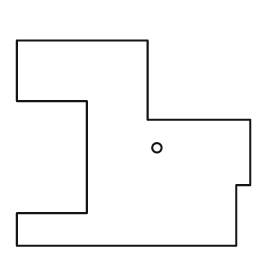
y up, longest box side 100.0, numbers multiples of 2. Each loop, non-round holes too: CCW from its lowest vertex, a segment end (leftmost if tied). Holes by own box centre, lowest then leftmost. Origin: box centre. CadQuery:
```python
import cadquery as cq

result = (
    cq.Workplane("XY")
    .moveTo(-50.0, -44.0)
    .lineTo(44.0, -44.0)
    .lineTo(44.0, -18.0)
    .lineTo(50.0, -18.0)
    .lineTo(50.0, 10.0)
    .lineTo(6.0, 10.0)
    .lineTo(6.0, 44.0)
    .lineTo(-50.0, 44.0)
    .lineTo(-50.0, 18.0)
    .lineTo(-20.0, 18.0)
    .lineTo(-20.0, -30.0)
    .lineTo(-50.0, -30.0)
    .close()
    .moveTo(10.0, -2.0)
    .circle(2.0)
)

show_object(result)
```